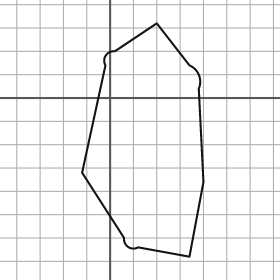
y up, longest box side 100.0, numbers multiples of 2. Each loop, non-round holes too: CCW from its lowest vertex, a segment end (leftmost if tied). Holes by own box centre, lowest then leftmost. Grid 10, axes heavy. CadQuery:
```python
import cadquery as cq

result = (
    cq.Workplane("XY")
    .moveTo(34.0, -68.0)
    .lineTo(40.0, -36.0)
    .lineTo(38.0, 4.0)
    .threePointArc((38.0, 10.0), (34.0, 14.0))
    .lineTo(20.0, 32.0)
    .lineTo(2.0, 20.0)
    .threePointArc((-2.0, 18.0), (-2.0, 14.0))
    .lineTo(-12.0, -32.0)
    .lineTo(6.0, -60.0)
    .threePointArc((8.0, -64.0), (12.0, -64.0))
    .close()
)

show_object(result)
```